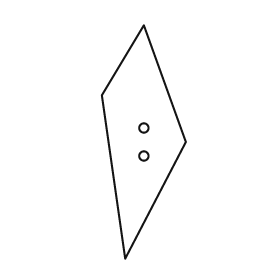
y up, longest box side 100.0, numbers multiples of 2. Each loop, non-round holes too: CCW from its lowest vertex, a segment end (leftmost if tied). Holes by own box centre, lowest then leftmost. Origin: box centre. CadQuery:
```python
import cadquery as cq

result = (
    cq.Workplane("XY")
    .moveTo(-8.0, -50.0)
    .lineTo(18.0, 0.0)
    .lineTo(0.0, 50.0)
    .lineTo(-18.0, 20.0)
    .close()
    .moveTo(0.0, -6.0)
    .circle(2.0)
    .moveTo(0.0, 6.0)
    .circle(2.0)
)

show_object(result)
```